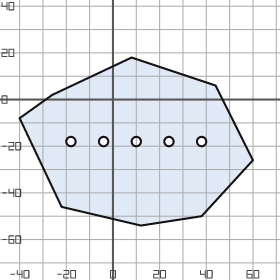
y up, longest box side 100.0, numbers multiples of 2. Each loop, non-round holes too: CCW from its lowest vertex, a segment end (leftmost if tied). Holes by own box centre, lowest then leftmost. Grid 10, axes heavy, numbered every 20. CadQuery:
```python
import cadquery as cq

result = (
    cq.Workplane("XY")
    .moveTo(12.0, -54.0)
    .lineTo(38.0, -50.0)
    .lineTo(60.0, -26.0)
    .lineTo(44.0, 6.0)
    .lineTo(8.0, 18.0)
    .lineTo(-26.0, 2.0)
    .lineTo(-40.0, -8.0)
    .lineTo(-22.0, -46.0)
    .close()
    .moveTo(-18.0, -18.0)
    .circle(2.0)
    .moveTo(-4.0, -18.0)
    .circle(2.0)
    .moveTo(10.0, -18.0)
    .circle(2.0)
    .moveTo(24.0, -18.0)
    .circle(2.0)
    .moveTo(38.0, -18.0)
    .circle(2.0)
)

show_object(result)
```